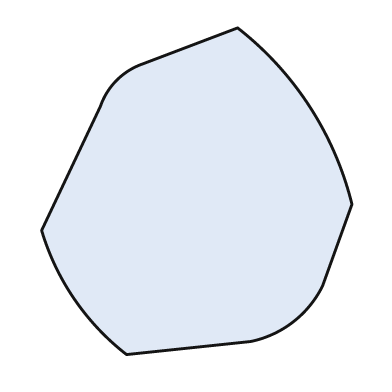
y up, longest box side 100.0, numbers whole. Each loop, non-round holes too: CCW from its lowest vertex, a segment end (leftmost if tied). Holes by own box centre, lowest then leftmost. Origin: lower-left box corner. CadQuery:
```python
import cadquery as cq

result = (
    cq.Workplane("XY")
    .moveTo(26.0, 0.0)
    .lineTo(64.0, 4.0)
    .threePointArc((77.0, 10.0), (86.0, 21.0))
    .lineTo(95.0, 46.0)
    .threePointArc((82.0, 76.0), (60.0, 100.0))
    .lineTo(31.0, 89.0)
    .threePointArc((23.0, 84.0), (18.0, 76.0))
    .lineTo(0.0, 38.0)
    .threePointArc((10.0, 17.0), (26.0, 0.0))
    .close()
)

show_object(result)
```